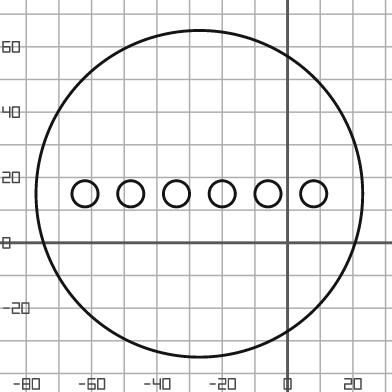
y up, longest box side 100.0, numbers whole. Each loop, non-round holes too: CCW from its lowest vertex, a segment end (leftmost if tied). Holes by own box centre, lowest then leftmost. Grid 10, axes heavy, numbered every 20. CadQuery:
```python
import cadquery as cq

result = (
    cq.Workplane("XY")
    .moveTo(-27.0, 15.0)
    .circle(50.0)
    .moveTo(-62.0, 15.0)
    .circle(4.0)
    .moveTo(-48.0, 15.0)
    .circle(4.0)
    .moveTo(-34.0, 15.0)
    .circle(4.0)
    .moveTo(-20.0, 15.0)
    .circle(4.0)
    .moveTo(-6.0, 15.0)
    .circle(4.0)
    .moveTo(8.0, 15.0)
    .circle(4.0)
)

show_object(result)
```